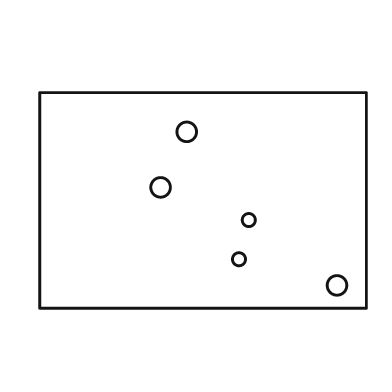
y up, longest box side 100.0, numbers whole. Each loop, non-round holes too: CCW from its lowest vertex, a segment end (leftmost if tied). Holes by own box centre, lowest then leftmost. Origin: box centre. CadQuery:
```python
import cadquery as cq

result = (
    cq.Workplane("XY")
    .moveTo(-50.0, -33.0)
    .lineTo(50.0, -33.0)
    .lineTo(50.0, 33.0)
    .lineTo(-50.0, 33.0)
    .close()
    .moveTo(41.0, -26.0)
    .circle(3.0)
    .moveTo(11.0, -18.0)
    .circle(2.0)
    .moveTo(14.0, -6.0)
    .circle(2.0)
    .moveTo(-13.0, 4.0)
    .circle(3.0)
    .moveTo(-5.0, 21.0)
    .circle(3.0)
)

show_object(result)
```